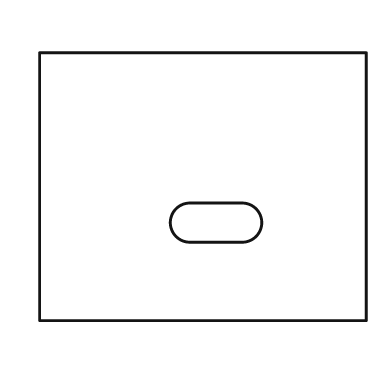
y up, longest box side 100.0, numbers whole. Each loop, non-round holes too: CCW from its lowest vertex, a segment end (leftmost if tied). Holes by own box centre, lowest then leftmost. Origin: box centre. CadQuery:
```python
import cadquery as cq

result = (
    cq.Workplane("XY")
    .moveTo(-50.0, -41.0)
    .lineTo(50.0, -41.0)
    .lineTo(50.0, 41.0)
    .lineTo(-50.0, 41.0)
    .close()
    .moveTo(-4.0, -17.0)
    .lineTo(12.0, -17.0)
    .threePointArc((18.0, -11.0), (12.0, -5.0))
    .lineTo(-4.0, -5.0)
    .threePointArc((-10.0, -11.0), (-4.0, -17.0))
    .close()
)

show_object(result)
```